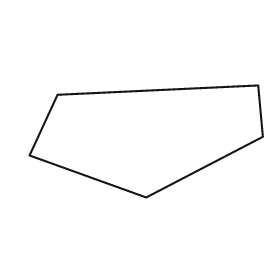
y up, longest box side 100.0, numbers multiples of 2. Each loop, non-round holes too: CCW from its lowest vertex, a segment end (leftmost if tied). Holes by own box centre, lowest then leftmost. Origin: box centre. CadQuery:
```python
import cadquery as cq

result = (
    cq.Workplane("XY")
    .moveTo(0.0, -24.0)
    .lineTo(50.0, 2.0)
    .lineTo(48.0, 24.0)
    .lineTo(-38.0, 20.0)
    .lineTo(-50.0, -6.0)
    .close()
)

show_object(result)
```